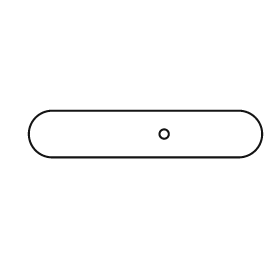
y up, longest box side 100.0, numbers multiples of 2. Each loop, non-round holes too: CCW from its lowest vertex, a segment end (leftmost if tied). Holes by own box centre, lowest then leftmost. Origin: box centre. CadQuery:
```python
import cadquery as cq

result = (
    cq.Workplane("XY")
    .moveTo(-40.0, -10.0)
    .lineTo(40.0, -10.0)
    .threePointArc((50.0, 0.0), (40.0, 10.0))
    .lineTo(-40.0, 10.0)
    .threePointArc((-50.0, 0.0), (-40.0, -10.0))
    .close()
    .moveTo(8.0, 0.0)
    .circle(2.0)
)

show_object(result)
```